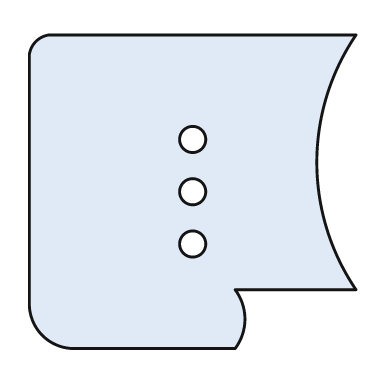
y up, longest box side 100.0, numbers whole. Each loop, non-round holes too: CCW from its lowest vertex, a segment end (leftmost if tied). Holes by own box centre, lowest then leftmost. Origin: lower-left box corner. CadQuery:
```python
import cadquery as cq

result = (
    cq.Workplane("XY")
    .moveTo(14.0, 0.0)
    .lineTo(63.0, 0.0)
    .threePointArc((66.0, 9.0), (63.0, 18.0))
    .lineTo(100.0, 18.0)
    .threePointArc((88.0, 57.0), (100.0, 96.0))
    .lineTo(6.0, 96.0)
    .threePointArc((2.0, 94.0), (0.0, 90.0))
    .lineTo(0.0, 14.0)
    .threePointArc((4.0, 4.0), (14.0, 0.0))
    .close()
    .moveTo(50.0, 32.0)
    .circle(4.0)
    .moveTo(50.0, 48.0)
    .circle(4.0)
    .moveTo(50.0, 64.0)
    .circle(4.0)
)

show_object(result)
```